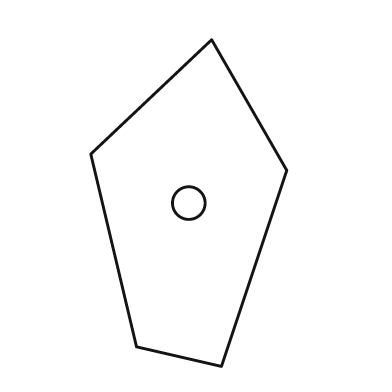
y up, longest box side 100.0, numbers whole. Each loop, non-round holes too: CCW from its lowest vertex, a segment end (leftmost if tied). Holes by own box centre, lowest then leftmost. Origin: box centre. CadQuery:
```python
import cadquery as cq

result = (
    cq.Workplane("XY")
    .moveTo(10.0, -50.0)
    .lineTo(30.0, 10.0)
    .lineTo(7.0, 50.0)
    .lineTo(-30.0, 15.0)
    .lineTo(-16.0, -44.0)
    .close()
    .moveTo(0.0, 0.0)
    .circle(5.0)
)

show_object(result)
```